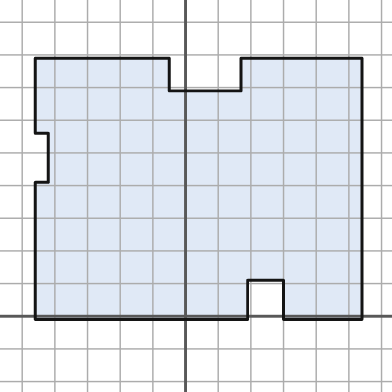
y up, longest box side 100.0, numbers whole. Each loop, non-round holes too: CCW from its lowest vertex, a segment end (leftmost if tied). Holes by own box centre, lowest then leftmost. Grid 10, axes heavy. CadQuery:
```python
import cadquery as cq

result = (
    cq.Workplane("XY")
    .moveTo(-46.0, -1.0)
    .lineTo(19.0, -1.0)
    .lineTo(19.0, 11.0)
    .lineTo(30.0, 11.0)
    .lineTo(30.0, -1.0)
    .lineTo(54.0, -1.0)
    .lineTo(54.0, 79.0)
    .lineTo(17.0, 79.0)
    .lineTo(17.0, 69.0)
    .lineTo(-5.0, 69.0)
    .lineTo(-5.0, 79.0)
    .lineTo(-46.0, 79.0)
    .lineTo(-46.0, 56.0)
    .lineTo(-42.0, 56.0)
    .lineTo(-42.0, 41.0)
    .lineTo(-46.0, 41.0)
    .close()
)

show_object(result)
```